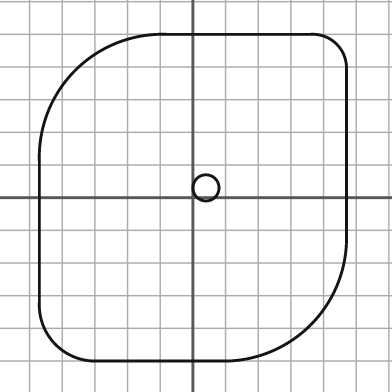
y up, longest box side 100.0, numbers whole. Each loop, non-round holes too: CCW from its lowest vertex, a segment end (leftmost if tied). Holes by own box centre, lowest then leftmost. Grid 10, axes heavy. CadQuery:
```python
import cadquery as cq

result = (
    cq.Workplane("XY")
    .moveTo(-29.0, -50.0)
    .lineTo(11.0, -50.0)
    .threePointArc((36.0, -39.0), (47.0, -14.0))
    .lineTo(47.0, 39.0)
    .threePointArc((44.0, 47.0), (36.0, 50.0))
    .lineTo(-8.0, 50.0)
    .threePointArc((-36.0, 39.0), (-47.0, 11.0))
    .lineTo(-47.0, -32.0)
    .threePointArc((-42.0, -45.0), (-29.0, -50.0))
    .close()
    .moveTo(4.0, 3.0)
    .circle(4.0)
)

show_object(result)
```